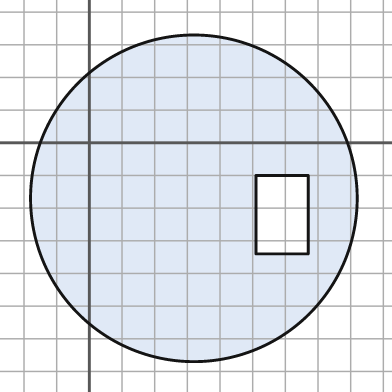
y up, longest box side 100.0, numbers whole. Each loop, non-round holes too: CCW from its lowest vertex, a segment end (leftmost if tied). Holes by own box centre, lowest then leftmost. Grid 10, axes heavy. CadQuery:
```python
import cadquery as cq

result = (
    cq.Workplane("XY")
    .moveTo(32.0, -17.0)
    .circle(50.0)
    .moveTo(51.0, -34.0)
    .lineTo(67.0, -34.0)
    .lineTo(67.0, -10.0)
    .lineTo(51.0, -10.0)
    .close()
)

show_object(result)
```